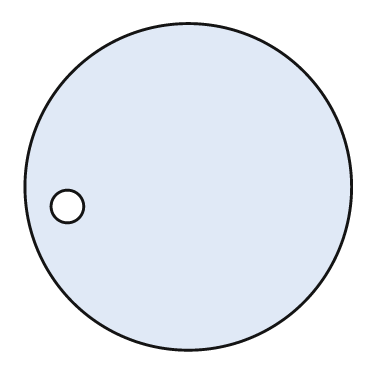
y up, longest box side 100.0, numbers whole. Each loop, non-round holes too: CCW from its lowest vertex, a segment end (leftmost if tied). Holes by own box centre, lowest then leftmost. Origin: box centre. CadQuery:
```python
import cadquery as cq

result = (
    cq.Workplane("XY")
    .moveTo(0.0, 0.0)
    .circle(50.0)
    .moveTo(-37.0, -6.0)
    .circle(5.0)
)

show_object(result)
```